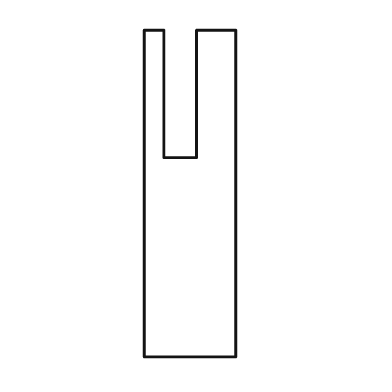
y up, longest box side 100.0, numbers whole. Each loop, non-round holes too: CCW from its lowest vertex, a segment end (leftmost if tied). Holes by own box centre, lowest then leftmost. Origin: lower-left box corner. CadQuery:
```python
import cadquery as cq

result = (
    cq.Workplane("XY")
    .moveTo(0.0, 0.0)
    .lineTo(28.0, 0.0)
    .lineTo(28.0, 100.0)
    .lineTo(16.0, 100.0)
    .lineTo(16.0, 61.0)
    .lineTo(6.0, 61.0)
    .lineTo(6.0, 100.0)
    .lineTo(0.0, 100.0)
    .close()
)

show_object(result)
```